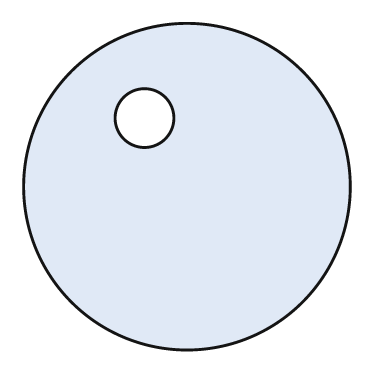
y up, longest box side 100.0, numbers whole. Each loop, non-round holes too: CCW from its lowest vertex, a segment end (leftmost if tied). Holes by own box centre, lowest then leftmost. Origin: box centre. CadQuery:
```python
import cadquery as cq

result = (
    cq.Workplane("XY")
    .moveTo(0.0, 0.0)
    .circle(50.0)
    .moveTo(-13.0, 21.0)
    .circle(9.0)
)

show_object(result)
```